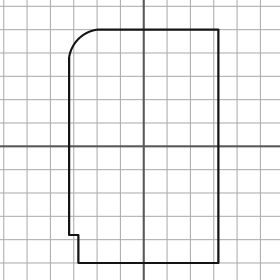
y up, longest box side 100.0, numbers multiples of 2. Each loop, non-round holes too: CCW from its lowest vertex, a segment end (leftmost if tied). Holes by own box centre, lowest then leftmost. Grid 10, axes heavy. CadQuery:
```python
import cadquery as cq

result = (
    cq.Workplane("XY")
    .moveTo(-28.0, -50.0)
    .lineTo(32.0, -50.0)
    .lineTo(32.0, 50.0)
    .lineTo(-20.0, 50.0)
    .threePointArc((-28.0, 46.0), (-32.0, 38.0))
    .lineTo(-32.0, -38.0)
    .lineTo(-28.0, -38.0)
    .close()
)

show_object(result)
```